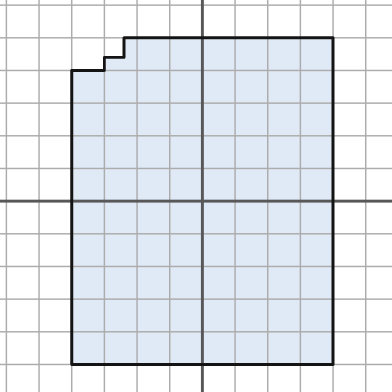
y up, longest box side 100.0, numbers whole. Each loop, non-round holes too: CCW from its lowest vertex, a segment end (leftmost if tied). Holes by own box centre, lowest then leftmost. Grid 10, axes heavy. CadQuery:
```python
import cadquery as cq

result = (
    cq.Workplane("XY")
    .moveTo(-40.0, -50.0)
    .lineTo(40.0, -50.0)
    .lineTo(40.0, 50.0)
    .lineTo(-24.0, 50.0)
    .lineTo(-24.0, 44.0)
    .lineTo(-30.0, 44.0)
    .lineTo(-30.0, 40.0)
    .lineTo(-40.0, 40.0)
    .close()
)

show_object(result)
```